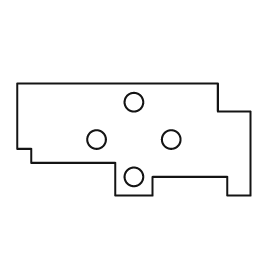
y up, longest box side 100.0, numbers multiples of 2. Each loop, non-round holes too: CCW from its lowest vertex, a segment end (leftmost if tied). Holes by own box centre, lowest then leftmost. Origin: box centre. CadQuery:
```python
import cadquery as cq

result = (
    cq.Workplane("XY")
    .moveTo(-8.0, -24.0)
    .lineTo(8.0, -24.0)
    .lineTo(8.0, -16.0)
    .lineTo(40.0, -16.0)
    .lineTo(40.0, -24.0)
    .lineTo(50.0, -24.0)
    .lineTo(50.0, 12.0)
    .lineTo(36.0, 12.0)
    .lineTo(36.0, 24.0)
    .lineTo(-50.0, 24.0)
    .lineTo(-50.0, -4.0)
    .lineTo(-44.0, -4.0)
    .lineTo(-44.0, -10.0)
    .lineTo(-8.0, -10.0)
    .close()
    .moveTo(0.0, -16.0)
    .circle(4.0)
    .moveTo(-16.0, 0.0)
    .circle(4.0)
    .moveTo(16.0, 0.0)
    .circle(4.0)
    .moveTo(0.0, 16.0)
    .circle(4.0)
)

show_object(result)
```